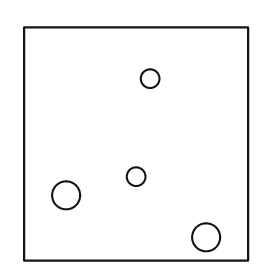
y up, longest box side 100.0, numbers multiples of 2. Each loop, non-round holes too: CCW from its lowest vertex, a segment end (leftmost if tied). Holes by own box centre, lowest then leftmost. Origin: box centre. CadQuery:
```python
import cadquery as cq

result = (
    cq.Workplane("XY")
    .moveTo(-48.0, -50.0)
    .lineTo(48.0, -50.0)
    .lineTo(48.0, 50.0)
    .lineTo(-48.0, 50.0)
    .close()
    .moveTo(30.0, -40.0)
    .circle(6.0)
    .moveTo(-30.0, -22.0)
    .circle(6.0)
    .moveTo(0.0, -14.0)
    .circle(4.0)
    .moveTo(6.0, 28.0)
    .circle(4.0)
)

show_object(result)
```